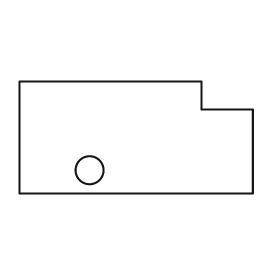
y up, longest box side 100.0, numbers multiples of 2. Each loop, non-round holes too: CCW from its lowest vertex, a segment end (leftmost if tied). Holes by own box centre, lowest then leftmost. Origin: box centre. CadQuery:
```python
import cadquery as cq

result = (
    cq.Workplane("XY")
    .moveTo(-50.0, -24.0)
    .lineTo(50.0, -24.0)
    .lineTo(50.0, 12.0)
    .lineTo(28.0, 12.0)
    .lineTo(28.0, 24.0)
    .lineTo(-50.0, 24.0)
    .close()
    .moveTo(-20.0, -14.0)
    .circle(6.0)
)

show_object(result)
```